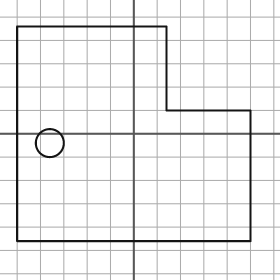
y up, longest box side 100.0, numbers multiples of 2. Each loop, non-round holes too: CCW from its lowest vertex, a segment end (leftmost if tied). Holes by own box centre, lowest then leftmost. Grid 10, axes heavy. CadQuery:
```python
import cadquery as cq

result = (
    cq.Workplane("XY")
    .moveTo(-50.0, -46.0)
    .lineTo(50.0, -46.0)
    .lineTo(50.0, 10.0)
    .lineTo(14.0, 10.0)
    .lineTo(14.0, 46.0)
    .lineTo(-50.0, 46.0)
    .close()
    .moveTo(-36.0, -4.0)
    .circle(6.0)
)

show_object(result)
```